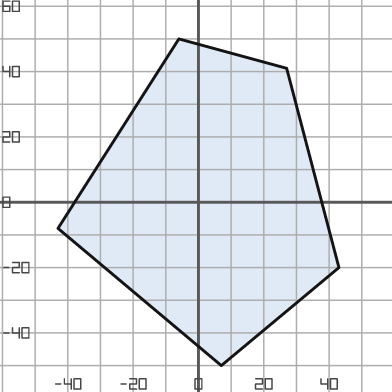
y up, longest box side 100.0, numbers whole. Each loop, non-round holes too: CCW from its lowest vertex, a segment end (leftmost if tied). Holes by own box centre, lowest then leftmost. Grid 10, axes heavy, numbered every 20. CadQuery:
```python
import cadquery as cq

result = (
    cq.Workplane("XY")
    .moveTo(7.0, -50.0)
    .lineTo(43.0, -20.0)
    .lineTo(27.0, 41.0)
    .lineTo(-6.0, 50.0)
    .lineTo(-43.0, -8.0)
    .close()
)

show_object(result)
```